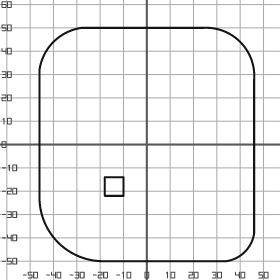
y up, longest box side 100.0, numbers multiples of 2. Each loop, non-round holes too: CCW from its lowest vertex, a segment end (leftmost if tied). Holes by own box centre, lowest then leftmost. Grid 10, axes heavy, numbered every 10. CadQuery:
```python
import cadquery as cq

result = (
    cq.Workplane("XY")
    .moveTo(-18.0, -50.0)
    .lineTo(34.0, -50.0)
    .threePointArc((42.0, -46.0), (46.0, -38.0))
    .lineTo(46.0, 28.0)
    .threePointArc((40.0, 44.0), (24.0, 50.0))
    .lineTo(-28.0, 50.0)
    .threePointArc((-40.0, 44.0), (-46.0, 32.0))
    .lineTo(-46.0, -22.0)
    .threePointArc((-38.0, -42.0), (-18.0, -50.0))
    .close()
    .moveTo(-18.0, -22.0)
    .lineTo(-10.0, -22.0)
    .lineTo(-10.0, -14.0)
    .lineTo(-18.0, -14.0)
    .close()
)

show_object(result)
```